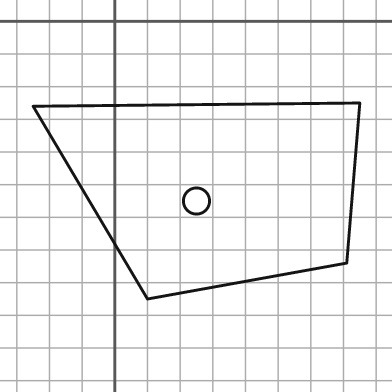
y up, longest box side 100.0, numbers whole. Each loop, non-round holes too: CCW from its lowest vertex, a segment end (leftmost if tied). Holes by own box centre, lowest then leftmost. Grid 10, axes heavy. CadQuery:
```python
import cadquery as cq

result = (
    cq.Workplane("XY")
    .moveTo(10.0, -85.0)
    .lineTo(71.0, -74.0)
    .lineTo(75.0, -25.0)
    .lineTo(-25.0, -26.0)
    .close()
    .moveTo(25.0, -55.0)
    .circle(4.0)
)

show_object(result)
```